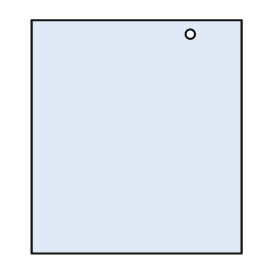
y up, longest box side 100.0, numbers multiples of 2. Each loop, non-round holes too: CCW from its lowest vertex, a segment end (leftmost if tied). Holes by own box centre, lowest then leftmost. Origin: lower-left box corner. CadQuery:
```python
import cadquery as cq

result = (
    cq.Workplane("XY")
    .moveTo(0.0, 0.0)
    .lineTo(90.0, 0.0)
    .lineTo(90.0, 100.0)
    .lineTo(0.0, 100.0)
    .close()
    .moveTo(68.0, 94.0)
    .circle(2.0)
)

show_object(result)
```